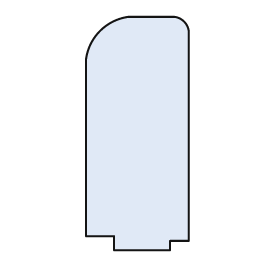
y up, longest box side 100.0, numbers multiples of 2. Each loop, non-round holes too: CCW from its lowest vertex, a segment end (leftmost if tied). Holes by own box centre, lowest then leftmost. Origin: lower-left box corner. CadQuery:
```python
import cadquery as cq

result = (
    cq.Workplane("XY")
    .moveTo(12.0, 0.0)
    .lineTo(36.0, 0.0)
    .lineTo(36.0, 4.0)
    .lineTo(44.0, 4.0)
    .lineTo(44.0, 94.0)
    .threePointArc((42.0, 98.0), (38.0, 100.0))
    .lineTo(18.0, 100.0)
    .threePointArc((6.0, 94.0), (0.0, 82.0))
    .lineTo(0.0, 6.0)
    .lineTo(12.0, 6.0)
    .close()
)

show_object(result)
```